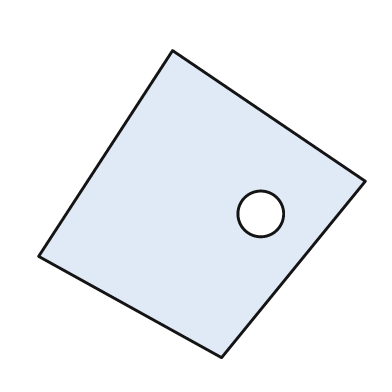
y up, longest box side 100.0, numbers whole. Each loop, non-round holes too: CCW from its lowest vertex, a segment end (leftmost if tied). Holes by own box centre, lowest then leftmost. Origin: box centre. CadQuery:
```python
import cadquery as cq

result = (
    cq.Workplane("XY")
    .moveTo(6.0, -47.0)
    .lineTo(50.0, 7.0)
    .lineTo(-9.0, 47.0)
    .lineTo(-50.0, -16.0)
    .close()
    .moveTo(18.0, -3.0)
    .circle(7.0)
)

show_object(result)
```